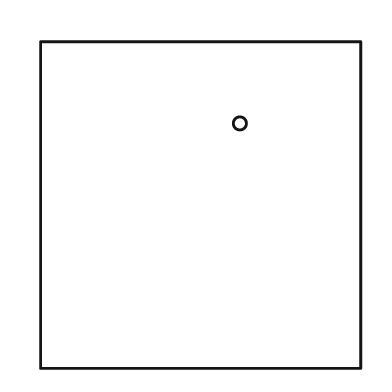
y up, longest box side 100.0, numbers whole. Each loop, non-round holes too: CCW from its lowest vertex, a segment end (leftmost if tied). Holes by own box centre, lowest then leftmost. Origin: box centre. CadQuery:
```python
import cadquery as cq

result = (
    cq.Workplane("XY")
    .moveTo(-49.0, -50.0)
    .lineTo(49.0, -50.0)
    .lineTo(49.0, 50.0)
    .lineTo(-49.0, 50.0)
    .close()
    .moveTo(12.0, 25.0)
    .circle(2.0)
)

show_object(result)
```